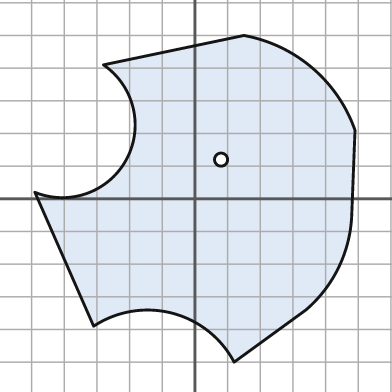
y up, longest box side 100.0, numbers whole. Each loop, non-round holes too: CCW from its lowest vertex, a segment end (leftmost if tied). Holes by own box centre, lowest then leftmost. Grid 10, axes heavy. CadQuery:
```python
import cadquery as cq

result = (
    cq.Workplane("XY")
    .moveTo(12.0, -50.0)
    .lineTo(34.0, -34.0)
    .threePointArc((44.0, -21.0), (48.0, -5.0))
    .lineTo(49.0, 21.0)
    .threePointArc((36.0, 40.0), (15.0, 50.0))
    .lineTo(-28.0, 41.0)
    .threePointArc((-21.0, 12.0), (-49.0, 2.0))
    .lineTo(-31.0, -39.0)
    .threePointArc((-7.0, -35.0), (12.0, -50.0))
    .close()
    .moveTo(8.0, 12.0)
    .circle(2.0)
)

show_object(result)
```